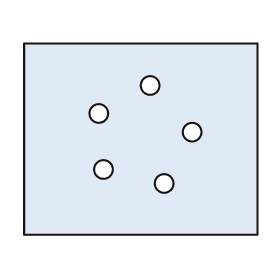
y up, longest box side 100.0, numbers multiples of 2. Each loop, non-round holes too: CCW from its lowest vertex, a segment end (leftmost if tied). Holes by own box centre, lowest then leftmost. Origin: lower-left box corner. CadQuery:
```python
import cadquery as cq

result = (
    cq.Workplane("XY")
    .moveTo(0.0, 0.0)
    .lineTo(100.0, 0.0)
    .lineTo(100.0, 82.0)
    .lineTo(0.0, 82.0)
    .close()
    .moveTo(60.0, 22.0)
    .circle(4.0)
    .moveTo(34.0, 28.0)
    .circle(4.0)
    .moveTo(72.0, 44.0)
    .circle(4.0)
    .moveTo(32.0, 52.0)
    .circle(4.0)
    .moveTo(54.0, 64.0)
    .circle(4.0)
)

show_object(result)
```